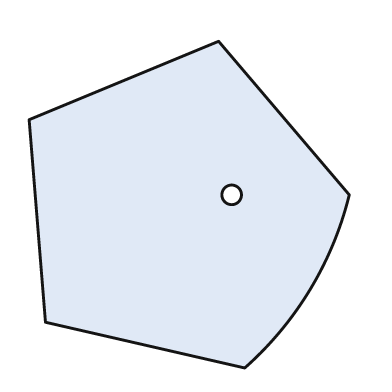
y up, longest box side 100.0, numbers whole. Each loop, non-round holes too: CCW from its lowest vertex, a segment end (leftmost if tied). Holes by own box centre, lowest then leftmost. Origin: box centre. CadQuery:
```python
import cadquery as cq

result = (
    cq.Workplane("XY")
    .moveTo(17.0, -50.0)
    .threePointArc((37.0, -26.0), (49.0, 3.0))
    .lineTo(9.0, 50.0)
    .lineTo(-49.0, 26.0)
    .lineTo(-44.0, -36.0)
    .close()
    .moveTo(13.0, 3.0)
    .circle(3.0)
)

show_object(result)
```